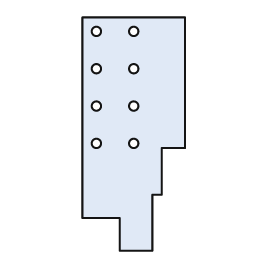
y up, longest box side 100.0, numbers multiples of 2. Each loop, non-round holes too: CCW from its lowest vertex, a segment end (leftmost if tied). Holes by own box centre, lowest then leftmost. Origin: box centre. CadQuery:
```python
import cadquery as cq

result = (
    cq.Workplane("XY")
    .moveTo(-6.0, -50.0)
    .lineTo(8.0, -50.0)
    .lineTo(8.0, -26.0)
    .lineTo(12.0, -26.0)
    .lineTo(12.0, -6.0)
    .lineTo(22.0, -6.0)
    .lineTo(22.0, 50.0)
    .lineTo(-22.0, 50.0)
    .lineTo(-22.0, -36.0)
    .lineTo(-6.0, -36.0)
    .close()
    .moveTo(-16.0, -4.0)
    .circle(2.0)
    .moveTo(0.0, -4.0)
    .circle(2.0)
    .moveTo(-16.0, 12.0)
    .circle(2.0)
    .moveTo(0.0, 12.0)
    .circle(2.0)
    .moveTo(-16.0, 28.0)
    .circle(2.0)
    .moveTo(0.0, 28.0)
    .circle(2.0)
    .moveTo(-16.0, 44.0)
    .circle(2.0)
    .moveTo(0.0, 44.0)
    .circle(2.0)
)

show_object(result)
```